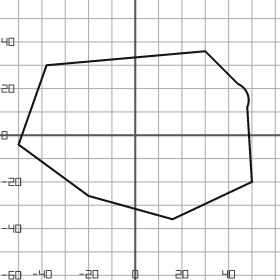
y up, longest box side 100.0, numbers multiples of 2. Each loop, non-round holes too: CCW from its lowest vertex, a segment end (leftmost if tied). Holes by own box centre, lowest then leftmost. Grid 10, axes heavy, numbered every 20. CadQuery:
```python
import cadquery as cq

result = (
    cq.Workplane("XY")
    .moveTo(16.0, -36.0)
    .lineTo(50.0, -20.0)
    .lineTo(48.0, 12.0)
    .threePointArc((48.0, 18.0), (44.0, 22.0))
    .lineTo(30.0, 36.0)
    .lineTo(-38.0, 30.0)
    .lineTo(-50.0, -4.0)
    .lineTo(-20.0, -26.0)
    .close()
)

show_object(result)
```